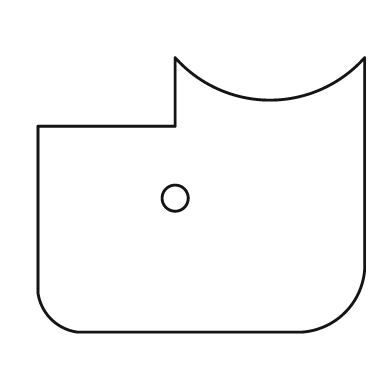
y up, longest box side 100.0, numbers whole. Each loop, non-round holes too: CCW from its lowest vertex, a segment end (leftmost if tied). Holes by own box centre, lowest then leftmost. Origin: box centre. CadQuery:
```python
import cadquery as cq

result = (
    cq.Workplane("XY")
    .moveTo(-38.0, -42.0)
    .lineTo(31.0, -42.0)
    .threePointArc((44.0, -36.0), (50.0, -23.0))
    .lineTo(50.0, 42.0)
    .threePointArc((21.0, 29.0), (-8.0, 42.0))
    .lineTo(-8.0, 21.0)
    .lineTo(-50.0, 21.0)
    .lineTo(-50.0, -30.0)
    .threePointArc((-46.0, -38.0), (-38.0, -42.0))
    .close()
    .moveTo(-8.0, -1.0)
    .circle(4.0)
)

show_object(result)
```